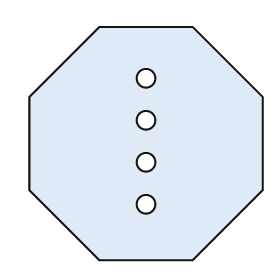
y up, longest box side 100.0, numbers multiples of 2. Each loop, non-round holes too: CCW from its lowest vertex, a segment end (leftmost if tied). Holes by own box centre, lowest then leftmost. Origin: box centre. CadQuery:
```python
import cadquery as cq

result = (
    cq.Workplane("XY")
    .moveTo(-20.0, -50.0)
    .lineTo(20.0, -50.0)
    .lineTo(50.0, -20.0)
    .lineTo(50.0, 20.0)
    .lineTo(20.0, 50.0)
    .lineTo(-20.0, 50.0)
    .lineTo(-50.0, 20.0)
    .lineTo(-50.0, -20.0)
    .close()
    .moveTo(0.0, -26.0)
    .circle(4.0)
    .moveTo(0.0, -8.0)
    .circle(4.0)
    .moveTo(0.0, 10.0)
    .circle(4.0)
    .moveTo(0.0, 28.0)
    .circle(4.0)
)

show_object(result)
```